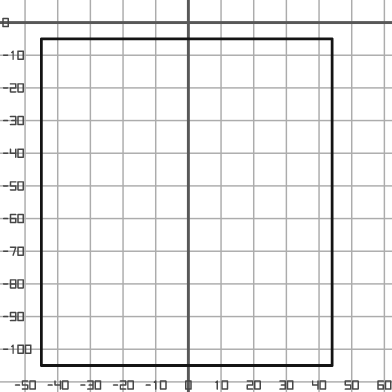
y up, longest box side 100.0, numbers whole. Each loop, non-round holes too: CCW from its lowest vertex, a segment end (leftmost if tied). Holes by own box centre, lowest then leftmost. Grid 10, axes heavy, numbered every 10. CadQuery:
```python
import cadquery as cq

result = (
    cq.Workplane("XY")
    .moveTo(-45.0, -105.0)
    .lineTo(44.0, -105.0)
    .lineTo(44.0, -5.0)
    .lineTo(-45.0, -5.0)
    .close()
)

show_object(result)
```